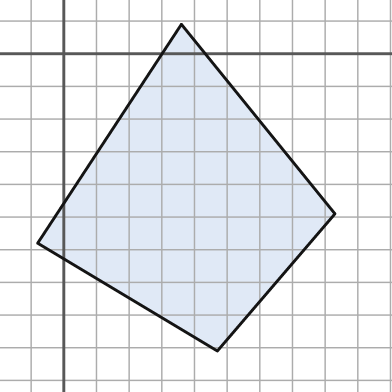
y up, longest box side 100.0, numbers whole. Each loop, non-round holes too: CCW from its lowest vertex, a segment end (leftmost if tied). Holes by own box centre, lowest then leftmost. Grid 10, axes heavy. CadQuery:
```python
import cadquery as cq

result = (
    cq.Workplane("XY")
    .moveTo(47.0, -91.0)
    .lineTo(83.0, -49.0)
    .lineTo(36.0, 9.0)
    .lineTo(-8.0, -58.0)
    .close()
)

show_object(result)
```